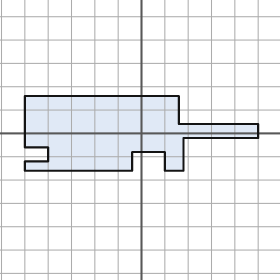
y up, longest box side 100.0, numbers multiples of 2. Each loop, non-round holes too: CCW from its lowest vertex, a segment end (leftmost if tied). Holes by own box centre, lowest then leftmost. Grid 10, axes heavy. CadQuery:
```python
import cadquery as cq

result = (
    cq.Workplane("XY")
    .moveTo(-50.0, -16.0)
    .lineTo(-4.0, -16.0)
    .lineTo(-4.0, -8.0)
    .lineTo(10.0, -8.0)
    .lineTo(10.0, -16.0)
    .lineTo(18.0, -16.0)
    .lineTo(18.0, -2.0)
    .lineTo(50.0, -2.0)
    .lineTo(50.0, 4.0)
    .lineTo(16.0, 4.0)
    .lineTo(16.0, 16.0)
    .lineTo(-50.0, 16.0)
    .lineTo(-50.0, -6.0)
    .lineTo(-40.0, -6.0)
    .lineTo(-40.0, -12.0)
    .lineTo(-50.0, -12.0)
    .close()
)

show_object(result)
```